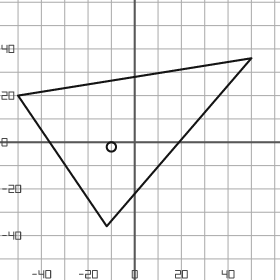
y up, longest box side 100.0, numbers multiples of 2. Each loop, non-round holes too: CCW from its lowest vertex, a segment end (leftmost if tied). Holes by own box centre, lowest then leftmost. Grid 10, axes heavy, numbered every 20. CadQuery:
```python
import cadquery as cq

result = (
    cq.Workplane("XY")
    .moveTo(-12.0, -36.0)
    .lineTo(50.0, 36.0)
    .lineTo(-50.0, 20.0)
    .close()
    .moveTo(-10.0, -2.0)
    .circle(2.0)
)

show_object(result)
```